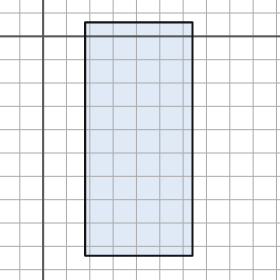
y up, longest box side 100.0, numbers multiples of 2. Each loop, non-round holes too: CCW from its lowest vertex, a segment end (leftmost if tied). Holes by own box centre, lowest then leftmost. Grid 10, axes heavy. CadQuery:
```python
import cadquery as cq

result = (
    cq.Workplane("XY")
    .moveTo(18.0, -94.0)
    .lineTo(64.0, -94.0)
    .lineTo(64.0, 6.0)
    .lineTo(18.0, 6.0)
    .close()
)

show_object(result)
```